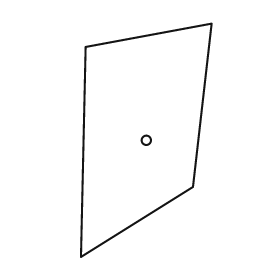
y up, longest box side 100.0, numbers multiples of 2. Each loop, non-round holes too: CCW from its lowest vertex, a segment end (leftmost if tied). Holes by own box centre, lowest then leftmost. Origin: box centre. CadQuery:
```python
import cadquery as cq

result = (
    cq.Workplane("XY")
    .moveTo(-28.0, -50.0)
    .lineTo(20.0, -20.0)
    .lineTo(28.0, 50.0)
    .lineTo(-26.0, 40.0)
    .close()
    .moveTo(0.0, 0.0)
    .circle(2.0)
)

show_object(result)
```